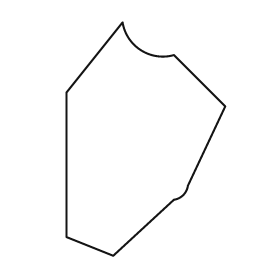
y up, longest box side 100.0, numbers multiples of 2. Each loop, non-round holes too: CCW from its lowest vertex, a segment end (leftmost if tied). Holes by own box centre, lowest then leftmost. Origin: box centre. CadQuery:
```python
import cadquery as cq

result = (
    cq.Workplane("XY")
    .moveTo(-14.0, -50.0)
    .lineTo(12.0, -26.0)
    .threePointArc((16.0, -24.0), (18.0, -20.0))
    .lineTo(34.0, 14.0)
    .lineTo(12.0, 36.0)
    .threePointArc((-2.0, 38.0), (-10.0, 50.0))
    .lineTo(-34.0, 20.0)
    .lineTo(-34.0, -42.0)
    .close()
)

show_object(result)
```